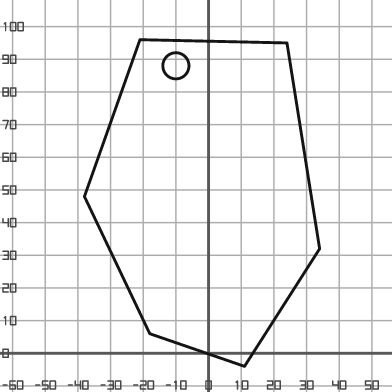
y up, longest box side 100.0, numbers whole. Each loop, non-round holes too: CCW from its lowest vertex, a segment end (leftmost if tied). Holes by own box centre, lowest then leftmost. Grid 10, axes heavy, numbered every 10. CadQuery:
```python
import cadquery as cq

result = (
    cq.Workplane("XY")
    .moveTo(11.0, -4.0)
    .lineTo(34.0, 32.0)
    .lineTo(24.0, 95.0)
    .lineTo(-21.0, 96.0)
    .lineTo(-38.0, 48.0)
    .lineTo(-18.0, 6.0)
    .close()
    .moveTo(-10.0, 88.0)
    .circle(4.0)
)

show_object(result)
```